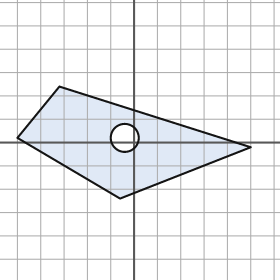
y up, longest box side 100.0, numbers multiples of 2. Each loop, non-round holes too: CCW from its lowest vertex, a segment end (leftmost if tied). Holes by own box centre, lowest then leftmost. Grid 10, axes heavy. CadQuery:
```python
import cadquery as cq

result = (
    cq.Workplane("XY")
    .moveTo(-6.0, -24.0)
    .lineTo(50.0, -2.0)
    .lineTo(-32.0, 24.0)
    .lineTo(-50.0, 2.0)
    .close()
    .moveTo(-4.0, 2.0)
    .circle(6.0)
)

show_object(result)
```